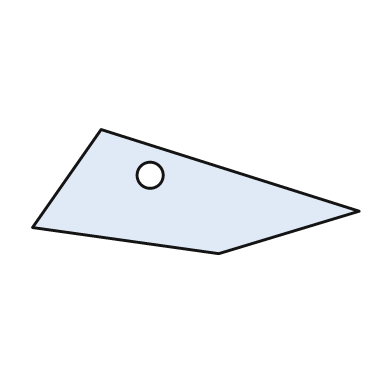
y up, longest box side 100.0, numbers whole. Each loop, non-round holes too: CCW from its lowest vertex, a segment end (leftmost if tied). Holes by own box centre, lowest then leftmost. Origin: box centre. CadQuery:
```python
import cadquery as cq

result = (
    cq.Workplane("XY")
    .moveTo(7.0, -19.0)
    .lineTo(50.0, -6.0)
    .lineTo(-29.0, 19.0)
    .lineTo(-50.0, -11.0)
    .close()
    .moveTo(-14.0, 5.0)
    .circle(4.0)
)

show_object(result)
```